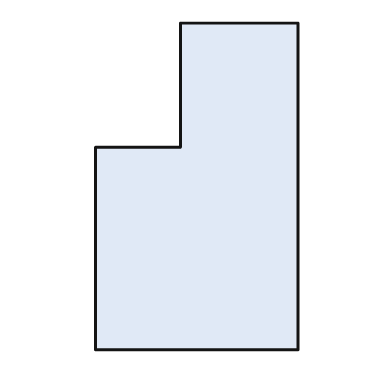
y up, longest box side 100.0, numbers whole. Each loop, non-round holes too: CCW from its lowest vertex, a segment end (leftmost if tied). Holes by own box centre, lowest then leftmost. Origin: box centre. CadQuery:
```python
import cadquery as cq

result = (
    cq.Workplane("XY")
    .moveTo(-31.0, -50.0)
    .lineTo(31.0, -50.0)
    .lineTo(31.0, 50.0)
    .lineTo(-5.0, 50.0)
    .lineTo(-5.0, 12.0)
    .lineTo(-31.0, 12.0)
    .close()
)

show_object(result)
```